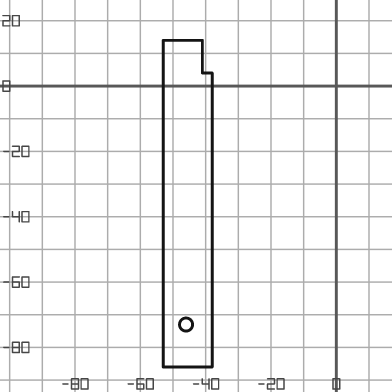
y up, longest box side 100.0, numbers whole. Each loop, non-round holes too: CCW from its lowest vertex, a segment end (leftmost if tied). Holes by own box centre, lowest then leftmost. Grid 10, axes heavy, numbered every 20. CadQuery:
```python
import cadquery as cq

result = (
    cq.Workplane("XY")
    .moveTo(-53.0, -86.0)
    .lineTo(-38.0, -86.0)
    .lineTo(-38.0, 4.0)
    .lineTo(-41.0, 4.0)
    .lineTo(-41.0, 14.0)
    .lineTo(-53.0, 14.0)
    .close()
    .moveTo(-46.0, -73.0)
    .circle(2.0)
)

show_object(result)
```